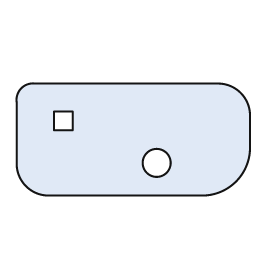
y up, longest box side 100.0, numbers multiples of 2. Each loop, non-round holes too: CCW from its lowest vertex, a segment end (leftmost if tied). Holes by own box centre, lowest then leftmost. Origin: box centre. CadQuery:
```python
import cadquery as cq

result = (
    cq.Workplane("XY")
    .moveTo(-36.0, -24.0)
    .lineTo(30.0, -24.0)
    .threePointArc((44.0, -18.0), (50.0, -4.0))
    .lineTo(50.0, 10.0)
    .threePointArc((46.0, 20.0), (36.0, 24.0))
    .lineTo(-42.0, 24.0)
    .threePointArc((-48.0, 22.0), (-50.0, 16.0))
    .lineTo(-50.0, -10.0)
    .threePointArc((-46.0, -20.0), (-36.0, -24.0))
    .close()
    .moveTo(10.0, -10.0)
    .circle(6.0)
    .moveTo(-34.0, 4.0)
    .lineTo(-26.0, 4.0)
    .lineTo(-26.0, 12.0)
    .lineTo(-34.0, 12.0)
    .close()
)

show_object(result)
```